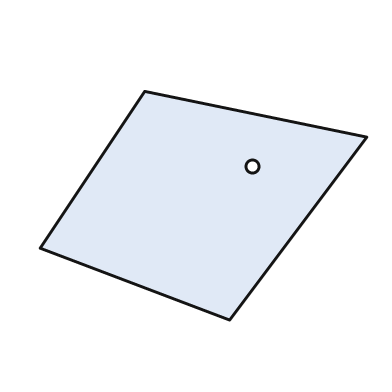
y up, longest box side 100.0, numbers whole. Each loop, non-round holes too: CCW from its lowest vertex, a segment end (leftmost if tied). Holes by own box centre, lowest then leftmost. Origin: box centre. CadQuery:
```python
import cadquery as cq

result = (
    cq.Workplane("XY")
    .moveTo(8.0, -35.0)
    .lineTo(50.0, 21.0)
    .lineTo(-18.0, 35.0)
    .lineTo(-50.0, -13.0)
    .close()
    .moveTo(15.0, 12.0)
    .circle(2.0)
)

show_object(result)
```